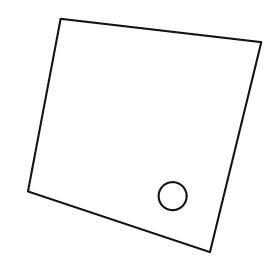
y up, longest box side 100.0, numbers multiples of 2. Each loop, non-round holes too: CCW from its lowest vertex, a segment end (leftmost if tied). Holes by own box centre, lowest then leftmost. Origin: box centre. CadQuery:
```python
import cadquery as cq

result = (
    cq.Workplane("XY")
    .moveTo(28.0, -50.0)
    .lineTo(50.0, 40.0)
    .lineTo(-36.0, 50.0)
    .lineTo(-50.0, -24.0)
    .close()
    .moveTo(12.0, -26.0)
    .circle(6.0)
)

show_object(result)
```